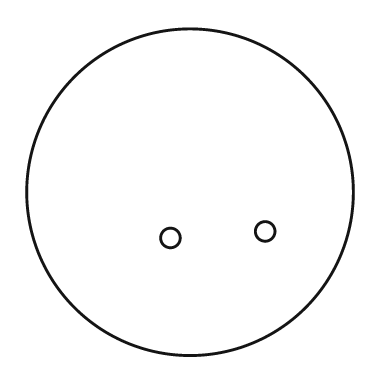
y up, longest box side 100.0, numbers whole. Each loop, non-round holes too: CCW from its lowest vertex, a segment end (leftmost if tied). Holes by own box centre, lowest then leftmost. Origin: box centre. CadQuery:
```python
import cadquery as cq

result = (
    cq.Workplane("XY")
    .moveTo(0.0, 0.0)
    .circle(50.0)
    .moveTo(-6.0, -14.0)
    .circle(3.0)
    .moveTo(23.0, -12.0)
    .circle(3.0)
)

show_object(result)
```